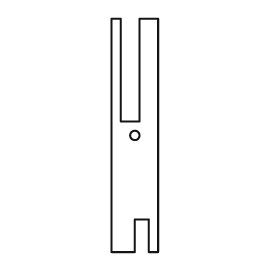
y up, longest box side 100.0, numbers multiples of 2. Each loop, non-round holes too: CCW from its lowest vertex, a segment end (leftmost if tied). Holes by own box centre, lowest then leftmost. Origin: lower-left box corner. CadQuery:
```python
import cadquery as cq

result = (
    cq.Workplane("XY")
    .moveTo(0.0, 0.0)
    .lineTo(10.0, 0.0)
    .lineTo(10.0, 14.0)
    .lineTo(16.0, 14.0)
    .lineTo(16.0, 0.0)
    .lineTo(20.0, 0.0)
    .lineTo(20.0, 100.0)
    .lineTo(12.0, 100.0)
    .lineTo(12.0, 56.0)
    .lineTo(4.0, 56.0)
    .lineTo(4.0, 100.0)
    .lineTo(0.0, 100.0)
    .close()
    .moveTo(10.0, 50.0)
    .circle(2.0)
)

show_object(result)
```